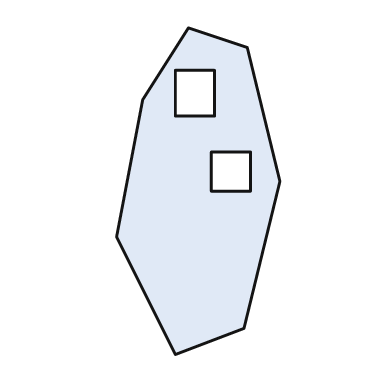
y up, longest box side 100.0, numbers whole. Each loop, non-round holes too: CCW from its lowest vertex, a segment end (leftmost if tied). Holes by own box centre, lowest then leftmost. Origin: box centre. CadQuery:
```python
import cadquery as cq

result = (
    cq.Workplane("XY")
    .moveTo(-7.0, -50.0)
    .lineTo(14.0, -42.0)
    .lineTo(25.0, 3.0)
    .lineTo(15.0, 44.0)
    .lineTo(-3.0, 50.0)
    .lineTo(-17.0, 28.0)
    .lineTo(-25.0, -14.0)
    .close()
    .moveTo(4.0, 0.0)
    .lineTo(16.0, 0.0)
    .lineTo(16.0, 12.0)
    .lineTo(4.0, 12.0)
    .close()
    .moveTo(-7.0, 23.0)
    .lineTo(5.0, 23.0)
    .lineTo(5.0, 37.0)
    .lineTo(-7.0, 37.0)
    .close()
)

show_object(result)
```